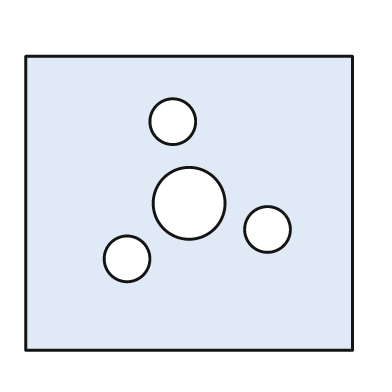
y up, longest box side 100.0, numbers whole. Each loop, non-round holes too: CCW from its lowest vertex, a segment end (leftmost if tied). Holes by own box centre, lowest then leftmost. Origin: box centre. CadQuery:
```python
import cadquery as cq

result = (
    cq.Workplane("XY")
    .moveTo(-50.0, -45.0)
    .lineTo(50.0, -45.0)
    .lineTo(50.0, 45.0)
    .lineTo(-50.0, 45.0)
    .close()
    .moveTo(-19.0, -17.0)
    .circle(7.0)
    .moveTo(24.0, -8.0)
    .circle(7.0)
    .moveTo(0.0, 0.0)
    .circle(11.0)
    .moveTo(-5.0, 25.0)
    .circle(7.0)
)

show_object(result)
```